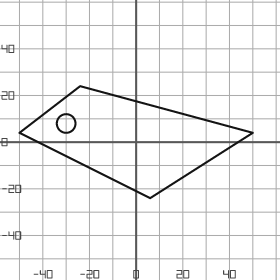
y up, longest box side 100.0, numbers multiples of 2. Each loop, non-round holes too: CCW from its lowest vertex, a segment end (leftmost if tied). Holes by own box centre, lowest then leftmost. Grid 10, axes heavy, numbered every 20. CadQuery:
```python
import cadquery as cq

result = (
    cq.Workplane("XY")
    .moveTo(6.0, -24.0)
    .lineTo(50.0, 4.0)
    .lineTo(-24.0, 24.0)
    .lineTo(-50.0, 4.0)
    .close()
    .moveTo(-30.0, 8.0)
    .circle(4.0)
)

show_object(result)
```